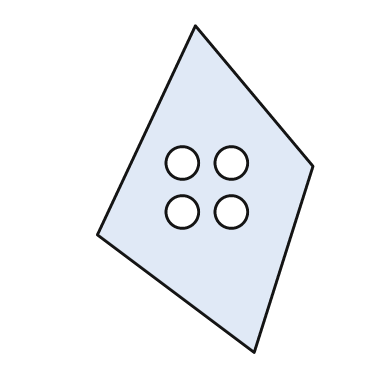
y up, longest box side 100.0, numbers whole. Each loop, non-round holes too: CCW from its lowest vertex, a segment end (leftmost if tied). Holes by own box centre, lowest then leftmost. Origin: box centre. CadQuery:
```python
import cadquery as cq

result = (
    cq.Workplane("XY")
    .moveTo(15.0, -50.0)
    .lineTo(33.0, 7.0)
    .lineTo(-3.0, 50.0)
    .lineTo(-33.0, -14.0)
    .close()
    .moveTo(-7.0, -7.0)
    .circle(5.0)
    .moveTo(8.0, -7.0)
    .circle(5.0)
    .moveTo(-7.0, 8.0)
    .circle(5.0)
    .moveTo(8.0, 8.0)
    .circle(5.0)
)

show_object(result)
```